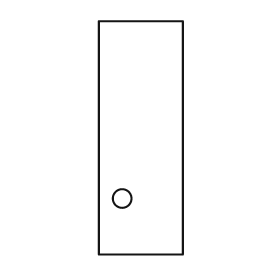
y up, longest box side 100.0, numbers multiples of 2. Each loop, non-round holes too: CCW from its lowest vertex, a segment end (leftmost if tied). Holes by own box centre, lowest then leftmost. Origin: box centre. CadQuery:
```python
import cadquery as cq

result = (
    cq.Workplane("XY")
    .moveTo(-18.0, -50.0)
    .lineTo(18.0, -50.0)
    .lineTo(18.0, 50.0)
    .lineTo(-18.0, 50.0)
    .close()
    .moveTo(-8.0, -26.0)
    .circle(4.0)
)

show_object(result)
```